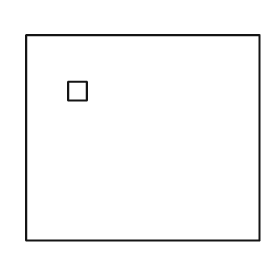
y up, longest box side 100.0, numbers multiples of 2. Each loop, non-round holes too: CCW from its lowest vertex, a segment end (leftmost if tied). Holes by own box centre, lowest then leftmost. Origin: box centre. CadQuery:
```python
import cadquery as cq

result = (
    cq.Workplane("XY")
    .moveTo(-50.0, -44.0)
    .lineTo(50.0, -44.0)
    .lineTo(50.0, 44.0)
    .lineTo(-50.0, 44.0)
    .close()
    .moveTo(-32.0, 16.0)
    .lineTo(-24.0, 16.0)
    .lineTo(-24.0, 24.0)
    .lineTo(-32.0, 24.0)
    .close()
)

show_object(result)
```